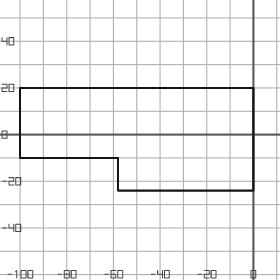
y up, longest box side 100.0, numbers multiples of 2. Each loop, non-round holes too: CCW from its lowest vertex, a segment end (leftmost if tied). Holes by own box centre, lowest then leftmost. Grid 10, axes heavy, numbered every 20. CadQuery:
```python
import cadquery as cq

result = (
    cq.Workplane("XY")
    .moveTo(-58.0, -24.0)
    .lineTo(0.0, -24.0)
    .lineTo(0.0, 20.0)
    .lineTo(-100.0, 20.0)
    .lineTo(-100.0, -10.0)
    .lineTo(-58.0, -10.0)
    .close()
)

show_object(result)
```